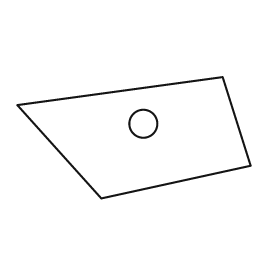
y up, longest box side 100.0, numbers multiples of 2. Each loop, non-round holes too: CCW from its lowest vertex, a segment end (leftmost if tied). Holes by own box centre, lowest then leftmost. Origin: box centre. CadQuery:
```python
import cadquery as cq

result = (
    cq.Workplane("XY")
    .moveTo(-14.0, -26.0)
    .lineTo(50.0, -12.0)
    .lineTo(38.0, 26.0)
    .lineTo(-50.0, 14.0)
    .close()
    .moveTo(4.0, 6.0)
    .circle(6.0)
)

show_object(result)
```